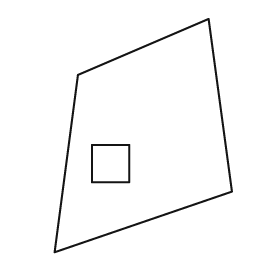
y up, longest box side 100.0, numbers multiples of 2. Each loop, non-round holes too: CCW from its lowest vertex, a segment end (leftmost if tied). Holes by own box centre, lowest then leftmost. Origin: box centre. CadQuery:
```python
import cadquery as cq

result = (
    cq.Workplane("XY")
    .moveTo(-38.0, -50.0)
    .lineTo(38.0, -24.0)
    .lineTo(28.0, 50.0)
    .lineTo(-28.0, 26.0)
    .close()
    .moveTo(-22.0, -20.0)
    .lineTo(-6.0, -20.0)
    .lineTo(-6.0, -4.0)
    .lineTo(-22.0, -4.0)
    .close()
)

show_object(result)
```